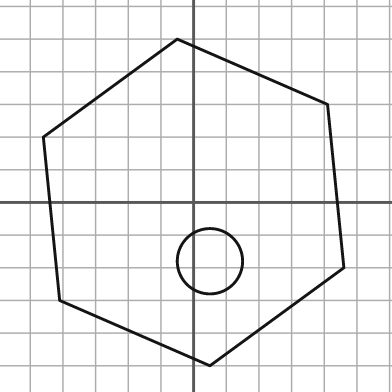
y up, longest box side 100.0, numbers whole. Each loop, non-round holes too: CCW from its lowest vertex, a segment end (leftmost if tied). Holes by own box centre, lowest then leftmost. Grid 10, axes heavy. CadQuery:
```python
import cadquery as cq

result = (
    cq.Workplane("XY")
    .moveTo(5.0, -50.0)
    .lineTo(46.0, -20.0)
    .lineTo(41.0, 30.0)
    .lineTo(-5.0, 50.0)
    .lineTo(-46.0, 20.0)
    .lineTo(-41.0, -30.0)
    .close()
    .moveTo(5.0, -18.0)
    .circle(10.0)
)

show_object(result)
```